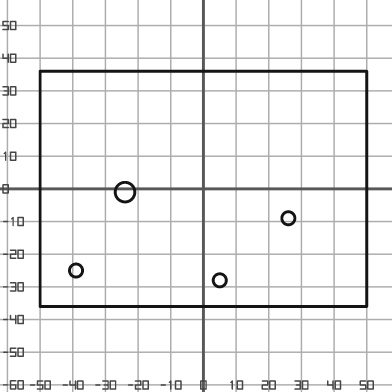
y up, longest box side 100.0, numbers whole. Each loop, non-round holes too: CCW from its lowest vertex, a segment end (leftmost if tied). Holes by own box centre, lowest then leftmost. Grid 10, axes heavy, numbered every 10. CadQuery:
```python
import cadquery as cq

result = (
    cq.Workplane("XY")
    .moveTo(-50.0, -36.0)
    .lineTo(50.0, -36.0)
    .lineTo(50.0, 36.0)
    .lineTo(-50.0, 36.0)
    .close()
    .moveTo(5.0, -28.0)
    .circle(2.0)
    .moveTo(-39.0, -25.0)
    .circle(2.0)
    .moveTo(26.0, -9.0)
    .circle(2.0)
    .moveTo(-24.0, -1.0)
    .circle(3.0)
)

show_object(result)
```